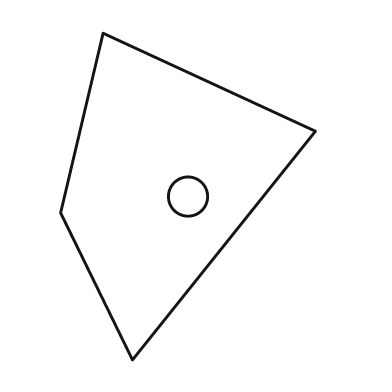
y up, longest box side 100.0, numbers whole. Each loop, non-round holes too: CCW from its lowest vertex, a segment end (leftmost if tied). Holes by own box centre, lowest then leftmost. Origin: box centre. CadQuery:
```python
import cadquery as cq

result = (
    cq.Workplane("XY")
    .moveTo(-17.0, -50.0)
    .lineTo(39.0, 20.0)
    .lineTo(-26.0, 50.0)
    .lineTo(-39.0, -5.0)
    .close()
    .moveTo(0.0, 0.0)
    .circle(6.0)
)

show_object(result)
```